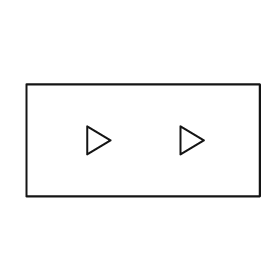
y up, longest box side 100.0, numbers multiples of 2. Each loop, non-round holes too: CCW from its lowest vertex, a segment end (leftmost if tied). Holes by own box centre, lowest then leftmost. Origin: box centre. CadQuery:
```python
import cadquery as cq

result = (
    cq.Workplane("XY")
    .moveTo(-50.0, -24.0)
    .lineTo(50.0, -24.0)
    .lineTo(50.0, 24.0)
    .lineTo(-50.0, 24.0)
    .close()
    .moveTo(-24.0, -6.0)
    .lineTo(-14.0, 0.0)
    .lineTo(-24.0, 6.0)
    .close()
    .moveTo(16.0, -6.0)
    .lineTo(26.0, 0.0)
    .lineTo(16.0, 6.0)
    .close()
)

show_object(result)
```